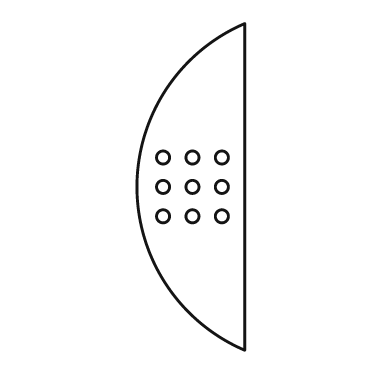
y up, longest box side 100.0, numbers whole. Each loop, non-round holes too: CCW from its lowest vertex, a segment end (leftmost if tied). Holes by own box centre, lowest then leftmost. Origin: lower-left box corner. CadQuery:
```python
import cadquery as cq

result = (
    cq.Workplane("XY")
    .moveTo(33.0, 0.0)
    .lineTo(33.0, 100.0)
    .threePointArc((0.0, 50.0), (33.0, 0.0))
    .close()
    .moveTo(8.0, 41.0)
    .circle(2.0)
    .moveTo(17.0, 41.0)
    .circle(2.0)
    .moveTo(26.0, 41.0)
    .circle(2.0)
    .moveTo(8.0, 50.0)
    .circle(2.0)
    .moveTo(17.0, 50.0)
    .circle(2.0)
    .moveTo(26.0, 50.0)
    .circle(2.0)
    .moveTo(8.0, 59.0)
    .circle(2.0)
    .moveTo(17.0, 59.0)
    .circle(2.0)
    .moveTo(26.0, 59.0)
    .circle(2.0)
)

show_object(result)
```